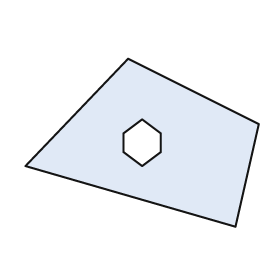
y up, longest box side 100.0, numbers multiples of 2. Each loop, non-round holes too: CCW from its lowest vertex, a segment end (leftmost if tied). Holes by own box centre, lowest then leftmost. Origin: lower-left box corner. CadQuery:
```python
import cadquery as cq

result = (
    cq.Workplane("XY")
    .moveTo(90.0, 0.0)
    .lineTo(100.0, 44.0)
    .lineTo(44.0, 72.0)
    .lineTo(0.0, 26.0)
    .close()
    .moveTo(50.0, 26.0)
    .lineTo(58.0, 32.0)
    .lineTo(58.0, 40.0)
    .lineTo(50.0, 46.0)
    .lineTo(42.0, 40.0)
    .lineTo(42.0, 32.0)
    .close()
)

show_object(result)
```